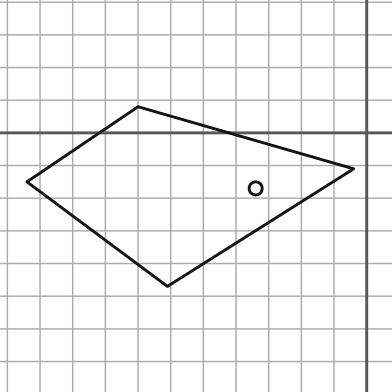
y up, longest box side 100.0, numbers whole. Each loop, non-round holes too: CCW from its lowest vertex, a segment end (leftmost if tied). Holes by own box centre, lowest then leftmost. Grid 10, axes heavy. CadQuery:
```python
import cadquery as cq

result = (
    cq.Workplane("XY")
    .moveTo(-61.0, -47.0)
    .lineTo(-4.0, -11.0)
    .lineTo(-70.0, 8.0)
    .lineTo(-104.0, -15.0)
    .close()
    .moveTo(-34.0, -17.0)
    .circle(2.0)
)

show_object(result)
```